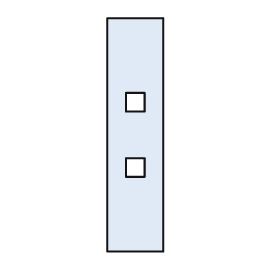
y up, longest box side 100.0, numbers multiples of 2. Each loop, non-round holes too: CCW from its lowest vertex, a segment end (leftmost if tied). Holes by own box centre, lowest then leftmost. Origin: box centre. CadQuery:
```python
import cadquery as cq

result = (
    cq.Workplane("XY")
    .moveTo(-12.0, -50.0)
    .lineTo(12.0, -50.0)
    .lineTo(12.0, 50.0)
    .lineTo(-12.0, 50.0)
    .close()
    .moveTo(-4.0, -18.0)
    .lineTo(4.0, -18.0)
    .lineTo(4.0, -10.0)
    .lineTo(-4.0, -10.0)
    .close()
    .moveTo(-4.0, 10.0)
    .lineTo(4.0, 10.0)
    .lineTo(4.0, 18.0)
    .lineTo(-4.0, 18.0)
    .close()
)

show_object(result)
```